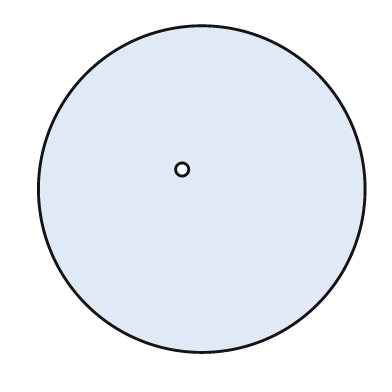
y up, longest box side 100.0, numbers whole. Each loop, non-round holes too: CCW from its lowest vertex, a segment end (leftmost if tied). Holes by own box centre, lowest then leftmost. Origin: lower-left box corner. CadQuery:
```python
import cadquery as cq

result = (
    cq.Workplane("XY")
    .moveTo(50.0, 50.0)
    .circle(50.0)
    .moveTo(44.0, 56.0)
    .circle(2.0)
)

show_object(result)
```